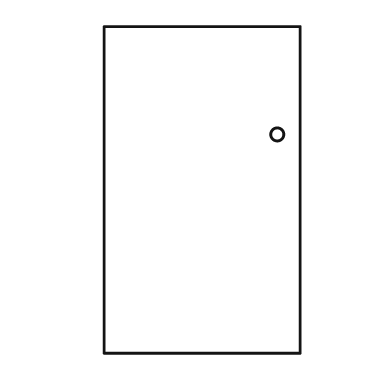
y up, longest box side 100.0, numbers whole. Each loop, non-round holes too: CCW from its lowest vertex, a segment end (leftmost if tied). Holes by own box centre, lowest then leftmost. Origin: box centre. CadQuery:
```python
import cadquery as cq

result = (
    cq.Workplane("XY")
    .moveTo(-30.0, -50.0)
    .lineTo(30.0, -50.0)
    .lineTo(30.0, 50.0)
    .lineTo(-30.0, 50.0)
    .close()
    .moveTo(23.0, 17.0)
    .circle(2.0)
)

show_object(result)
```